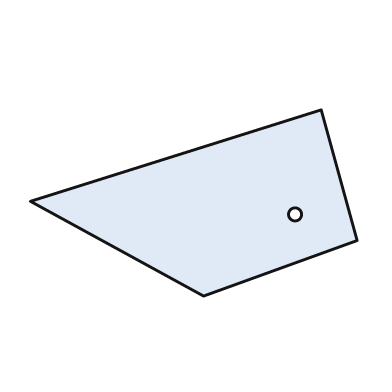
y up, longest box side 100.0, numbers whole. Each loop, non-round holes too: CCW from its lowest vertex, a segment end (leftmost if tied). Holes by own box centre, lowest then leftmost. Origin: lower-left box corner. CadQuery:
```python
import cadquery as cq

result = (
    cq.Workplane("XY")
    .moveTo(53.0, 0.0)
    .lineTo(100.0, 17.0)
    .lineTo(89.0, 57.0)
    .lineTo(0.0, 29.0)
    .close()
    .moveTo(81.0, 25.0)
    .circle(2.0)
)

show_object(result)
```